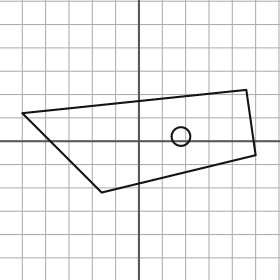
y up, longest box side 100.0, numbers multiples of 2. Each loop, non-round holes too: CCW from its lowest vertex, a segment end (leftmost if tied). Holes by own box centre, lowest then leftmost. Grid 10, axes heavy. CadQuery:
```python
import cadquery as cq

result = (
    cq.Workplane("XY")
    .moveTo(-16.0, -22.0)
    .lineTo(50.0, -6.0)
    .lineTo(46.0, 22.0)
    .lineTo(-50.0, 12.0)
    .close()
    .moveTo(18.0, 2.0)
    .circle(4.0)
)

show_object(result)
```